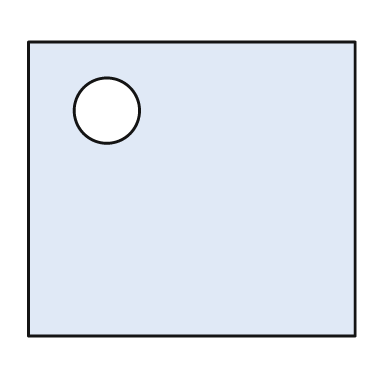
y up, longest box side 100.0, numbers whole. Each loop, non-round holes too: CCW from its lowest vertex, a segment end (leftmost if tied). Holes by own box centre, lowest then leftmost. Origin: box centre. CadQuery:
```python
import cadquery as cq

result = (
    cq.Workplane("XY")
    .moveTo(-50.0, -45.0)
    .lineTo(50.0, -45.0)
    .lineTo(50.0, 45.0)
    .lineTo(-50.0, 45.0)
    .close()
    .moveTo(-26.0, 24.0)
    .circle(10.0)
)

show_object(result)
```